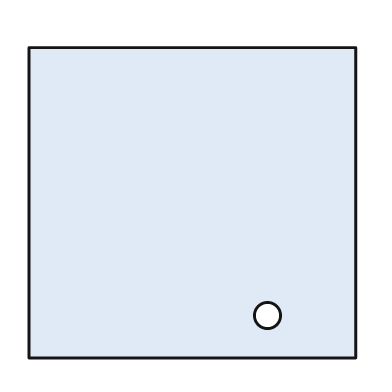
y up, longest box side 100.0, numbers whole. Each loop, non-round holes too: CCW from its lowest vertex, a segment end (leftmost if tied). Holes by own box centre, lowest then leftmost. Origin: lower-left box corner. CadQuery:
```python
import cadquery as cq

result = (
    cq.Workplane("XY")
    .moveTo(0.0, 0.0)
    .lineTo(100.0, 0.0)
    .lineTo(100.0, 95.0)
    .lineTo(0.0, 95.0)
    .close()
    .moveTo(73.0, 13.0)
    .circle(4.0)
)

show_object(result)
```